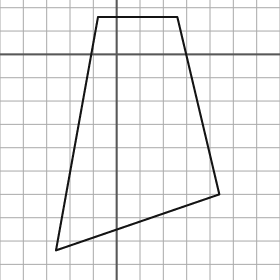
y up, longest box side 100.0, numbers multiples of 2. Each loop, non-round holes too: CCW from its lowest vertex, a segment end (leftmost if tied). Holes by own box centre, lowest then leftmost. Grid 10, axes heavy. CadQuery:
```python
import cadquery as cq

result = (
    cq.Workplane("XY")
    .moveTo(-26.0, -84.0)
    .lineTo(44.0, -60.0)
    .lineTo(26.0, 16.0)
    .lineTo(-8.0, 16.0)
    .close()
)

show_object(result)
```